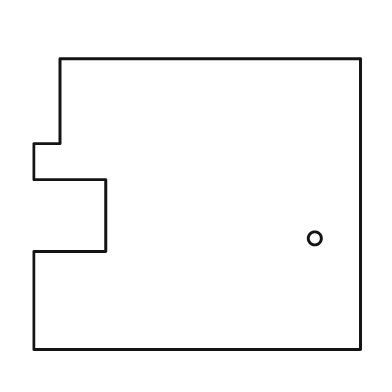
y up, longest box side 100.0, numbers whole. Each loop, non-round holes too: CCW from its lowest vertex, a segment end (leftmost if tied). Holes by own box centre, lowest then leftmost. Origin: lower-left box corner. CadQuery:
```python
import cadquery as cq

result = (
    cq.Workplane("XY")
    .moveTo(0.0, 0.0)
    .lineTo(100.0, 0.0)
    .lineTo(100.0, 89.0)
    .lineTo(8.0, 89.0)
    .lineTo(8.0, 63.0)
    .lineTo(0.0, 63.0)
    .lineTo(0.0, 52.0)
    .lineTo(22.0, 52.0)
    .lineTo(22.0, 30.0)
    .lineTo(0.0, 30.0)
    .close()
    .moveTo(86.0, 34.0)
    .circle(2.0)
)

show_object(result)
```